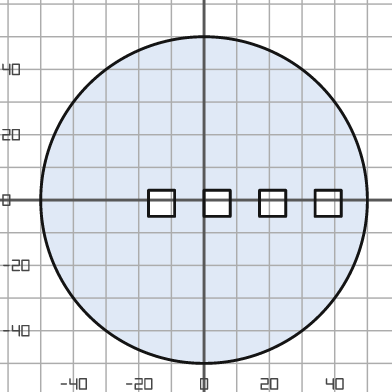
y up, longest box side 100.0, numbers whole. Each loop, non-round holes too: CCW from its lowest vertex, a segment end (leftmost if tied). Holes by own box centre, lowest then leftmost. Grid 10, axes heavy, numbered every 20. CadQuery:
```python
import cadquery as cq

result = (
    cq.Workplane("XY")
    .moveTo(0.0, 0.0)
    .circle(50.0)
    .moveTo(-17.0, -5.0)
    .lineTo(-9.0, -5.0)
    .lineTo(-9.0, 3.0)
    .lineTo(-17.0, 3.0)
    .close()
    .moveTo(0.0, -5.0)
    .lineTo(8.0, -5.0)
    .lineTo(8.0, 3.0)
    .lineTo(0.0, 3.0)
    .close()
    .moveTo(17.0, -5.0)
    .lineTo(25.0, -5.0)
    .lineTo(25.0, 3.0)
    .lineTo(17.0, 3.0)
    .close()
    .moveTo(34.0, -5.0)
    .lineTo(42.0, -5.0)
    .lineTo(42.0, 3.0)
    .lineTo(34.0, 3.0)
    .close()
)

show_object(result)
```